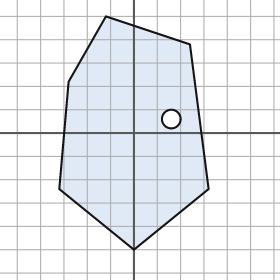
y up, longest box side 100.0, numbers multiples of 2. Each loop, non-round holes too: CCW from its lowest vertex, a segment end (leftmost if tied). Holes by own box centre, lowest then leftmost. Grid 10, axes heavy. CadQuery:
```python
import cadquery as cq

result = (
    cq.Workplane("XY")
    .moveTo(0.0, -50.0)
    .lineTo(32.0, -24.0)
    .lineTo(24.0, 38.0)
    .lineTo(-12.0, 50.0)
    .lineTo(-28.0, 22.0)
    .lineTo(-32.0, -24.0)
    .close()
    .moveTo(16.0, 6.0)
    .circle(4.0)
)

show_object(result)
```